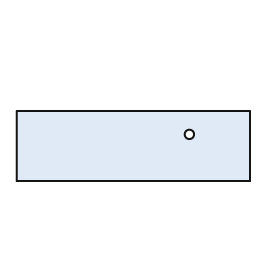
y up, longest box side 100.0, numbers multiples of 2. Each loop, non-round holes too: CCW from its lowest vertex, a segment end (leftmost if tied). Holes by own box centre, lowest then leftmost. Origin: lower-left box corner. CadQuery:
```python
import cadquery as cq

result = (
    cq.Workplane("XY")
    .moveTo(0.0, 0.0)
    .lineTo(100.0, 0.0)
    .lineTo(100.0, 30.0)
    .lineTo(0.0, 30.0)
    .close()
    .moveTo(74.0, 20.0)
    .circle(2.0)
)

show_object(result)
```